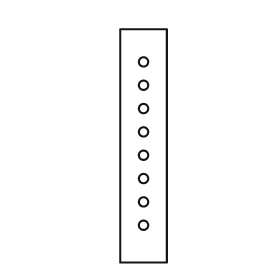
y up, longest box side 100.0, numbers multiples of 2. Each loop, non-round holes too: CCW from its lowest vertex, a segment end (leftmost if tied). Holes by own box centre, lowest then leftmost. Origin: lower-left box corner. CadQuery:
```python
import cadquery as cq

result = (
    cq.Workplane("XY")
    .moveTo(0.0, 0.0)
    .lineTo(20.0, 0.0)
    .lineTo(20.0, 100.0)
    .lineTo(0.0, 100.0)
    .close()
    .moveTo(10.0, 16.0)
    .circle(2.0)
    .moveTo(10.0, 26.0)
    .circle(2.0)
    .moveTo(10.0, 36.0)
    .circle(2.0)
    .moveTo(10.0, 46.0)
    .circle(2.0)
    .moveTo(10.0, 56.0)
    .circle(2.0)
    .moveTo(10.0, 66.0)
    .circle(2.0)
    .moveTo(10.0, 76.0)
    .circle(2.0)
    .moveTo(10.0, 86.0)
    .circle(2.0)
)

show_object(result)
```